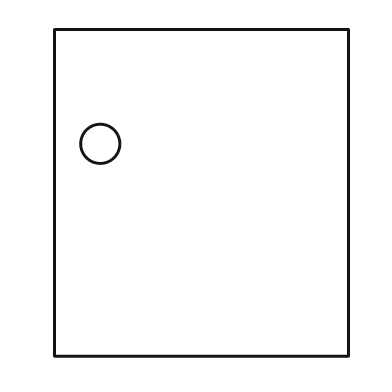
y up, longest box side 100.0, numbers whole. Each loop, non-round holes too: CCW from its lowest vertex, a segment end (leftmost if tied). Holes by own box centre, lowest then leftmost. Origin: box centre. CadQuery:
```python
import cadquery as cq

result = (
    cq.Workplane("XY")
    .moveTo(-45.0, -50.0)
    .lineTo(45.0, -50.0)
    .lineTo(45.0, 50.0)
    .lineTo(-45.0, 50.0)
    .close()
    .moveTo(-31.0, 15.0)
    .circle(6.0)
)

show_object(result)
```